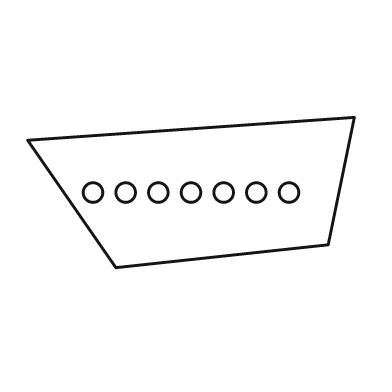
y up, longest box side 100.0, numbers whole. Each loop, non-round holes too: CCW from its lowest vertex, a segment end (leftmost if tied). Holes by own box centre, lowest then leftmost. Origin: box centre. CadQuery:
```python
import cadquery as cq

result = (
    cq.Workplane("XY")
    .moveTo(-23.0, -23.0)
    .lineTo(42.0, -16.0)
    .lineTo(50.0, 23.0)
    .lineTo(-50.0, 16.0)
    .close()
    .moveTo(-30.0, 0.0)
    .circle(3.0)
    .moveTo(-20.0, 0.0)
    .circle(3.0)
    .moveTo(-10.0, 0.0)
    .circle(3.0)
    .moveTo(0.0, 0.0)
    .circle(3.0)
    .moveTo(10.0, 0.0)
    .circle(3.0)
    .moveTo(20.0, 0.0)
    .circle(3.0)
    .moveTo(30.0, 0.0)
    .circle(3.0)
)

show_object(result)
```